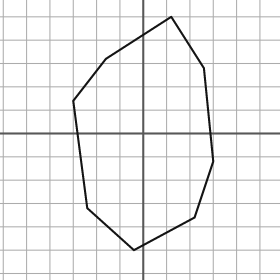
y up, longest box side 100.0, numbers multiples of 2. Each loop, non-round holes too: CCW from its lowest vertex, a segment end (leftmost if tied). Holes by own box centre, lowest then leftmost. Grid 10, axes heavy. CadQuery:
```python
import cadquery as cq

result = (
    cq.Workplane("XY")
    .moveTo(-4.0, -50.0)
    .lineTo(22.0, -36.0)
    .lineTo(30.0, -12.0)
    .lineTo(26.0, 28.0)
    .lineTo(12.0, 50.0)
    .lineTo(-16.0, 32.0)
    .lineTo(-30.0, 14.0)
    .lineTo(-24.0, -32.0)
    .close()
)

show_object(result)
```